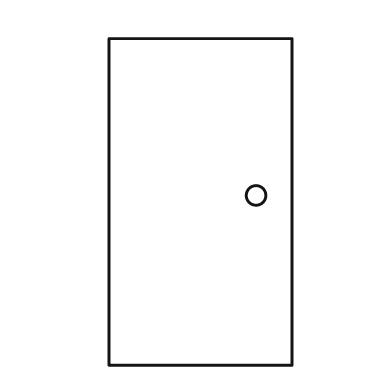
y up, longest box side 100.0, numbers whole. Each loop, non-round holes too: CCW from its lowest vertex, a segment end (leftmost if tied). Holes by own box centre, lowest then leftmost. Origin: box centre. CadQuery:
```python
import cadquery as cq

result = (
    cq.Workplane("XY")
    .moveTo(-28.0, -50.0)
    .lineTo(28.0, -50.0)
    .lineTo(28.0, 50.0)
    .lineTo(-28.0, 50.0)
    .close()
    .moveTo(17.0, 2.0)
    .circle(3.0)
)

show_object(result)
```